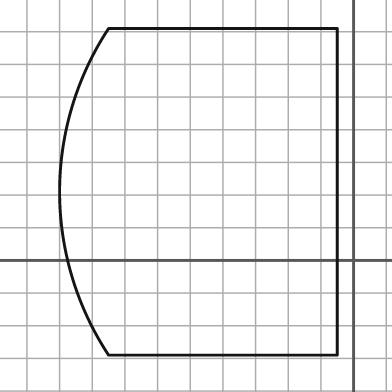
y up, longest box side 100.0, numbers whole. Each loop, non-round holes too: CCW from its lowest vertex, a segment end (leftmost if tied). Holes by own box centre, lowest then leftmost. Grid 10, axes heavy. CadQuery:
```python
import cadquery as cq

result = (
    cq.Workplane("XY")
    .moveTo(-75.0, -29.0)
    .lineTo(-5.0, -29.0)
    .lineTo(-5.0, 71.0)
    .lineTo(-75.0, 71.0)
    .threePointArc((-90.0, 21.0), (-75.0, -29.0))
    .close()
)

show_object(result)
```